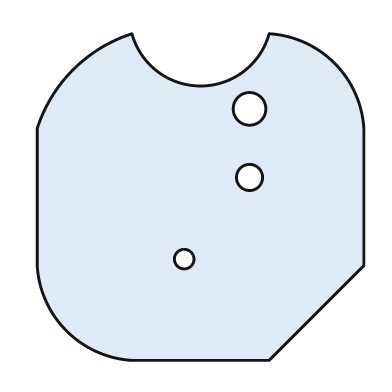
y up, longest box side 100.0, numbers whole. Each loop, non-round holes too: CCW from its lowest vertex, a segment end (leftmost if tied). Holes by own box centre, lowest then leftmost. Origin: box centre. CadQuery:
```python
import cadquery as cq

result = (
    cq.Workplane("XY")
    .moveTo(-21.0, -50.0)
    .lineTo(21.0, -50.0)
    .lineTo(50.0, -21.0)
    .lineTo(50.0, 21.0)
    .threePointArc((41.0, 41.0), (21.0, 50.0))
    .threePointArc((0.0, 34.0), (-21.0, 50.0))
    .threePointArc((-39.0, 39.0), (-50.0, 21.0))
    .lineTo(-50.0, -21.0)
    .threePointArc((-41.0, -41.0), (-21.0, -50.0))
    .close()
    .moveTo(-5.0, -19.0)
    .circle(3.0)
    .moveTo(15.0, 6.0)
    .circle(4.0)
    .moveTo(15.0, 27.0)
    .circle(5.0)
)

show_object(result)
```